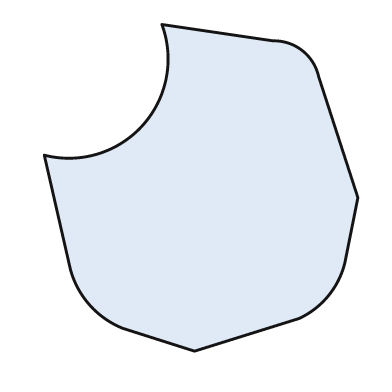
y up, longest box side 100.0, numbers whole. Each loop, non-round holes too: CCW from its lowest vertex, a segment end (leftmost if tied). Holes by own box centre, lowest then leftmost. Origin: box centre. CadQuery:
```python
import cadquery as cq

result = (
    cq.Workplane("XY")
    .moveTo(-2.0, -50.0)
    .lineTo(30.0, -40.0)
    .threePointArc((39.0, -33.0), (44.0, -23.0))
    .lineTo(48.0, -3.0)
    .lineTo(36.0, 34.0)
    .threePointArc((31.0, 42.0), (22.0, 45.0))
    .lineTo(-12.0, 50.0)
    .threePointArc((-18.0, 19.0), (-48.0, 10.0))
    .lineTo(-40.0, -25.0)
    .threePointArc((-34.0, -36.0), (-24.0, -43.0))
    .close()
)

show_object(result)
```